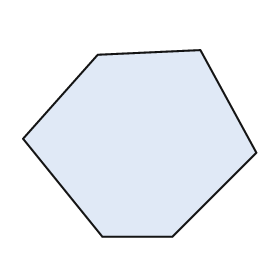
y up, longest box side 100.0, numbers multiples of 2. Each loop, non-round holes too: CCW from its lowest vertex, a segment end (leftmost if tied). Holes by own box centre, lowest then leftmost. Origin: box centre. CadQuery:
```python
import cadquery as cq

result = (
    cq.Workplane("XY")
    .moveTo(-16.0, -40.0)
    .lineTo(14.0, -40.0)
    .lineTo(50.0, -4.0)
    .lineTo(26.0, 40.0)
    .lineTo(-18.0, 38.0)
    .lineTo(-50.0, 2.0)
    .close()
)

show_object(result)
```